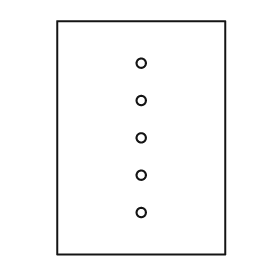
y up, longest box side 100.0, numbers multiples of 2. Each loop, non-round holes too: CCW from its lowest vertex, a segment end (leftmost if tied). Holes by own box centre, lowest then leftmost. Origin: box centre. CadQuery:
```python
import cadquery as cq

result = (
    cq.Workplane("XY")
    .moveTo(-36.0, -50.0)
    .lineTo(36.0, -50.0)
    .lineTo(36.0, 50.0)
    .lineTo(-36.0, 50.0)
    .close()
    .moveTo(0.0, -32.0)
    .circle(2.0)
    .moveTo(0.0, -16.0)
    .circle(2.0)
    .moveTo(0.0, 0.0)
    .circle(2.0)
    .moveTo(0.0, 16.0)
    .circle(2.0)
    .moveTo(0.0, 32.0)
    .circle(2.0)
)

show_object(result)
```